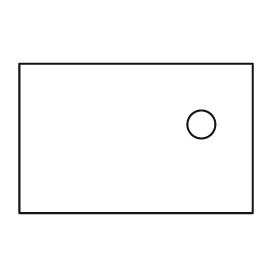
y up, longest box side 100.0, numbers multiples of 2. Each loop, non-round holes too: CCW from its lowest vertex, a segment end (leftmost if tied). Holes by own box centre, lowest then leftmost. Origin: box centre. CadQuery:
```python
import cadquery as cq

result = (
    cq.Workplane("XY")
    .moveTo(-50.0, -32.0)
    .lineTo(50.0, -32.0)
    .lineTo(50.0, 32.0)
    .lineTo(-50.0, 32.0)
    .close()
    .moveTo(28.0, 6.0)
    .circle(6.0)
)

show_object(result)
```